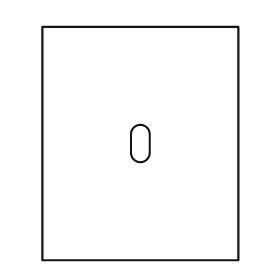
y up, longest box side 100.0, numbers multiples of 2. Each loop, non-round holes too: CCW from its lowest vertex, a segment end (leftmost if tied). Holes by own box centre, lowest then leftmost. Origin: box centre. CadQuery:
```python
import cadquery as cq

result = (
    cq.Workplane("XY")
    .moveTo(-42.0, -50.0)
    .lineTo(42.0, -50.0)
    .lineTo(42.0, 50.0)
    .lineTo(-42.0, 50.0)
    .close()
    .moveTo(-4.0, -4.0)
    .threePointArc((0.0, -8.0), (4.0, -4.0))
    .lineTo(4.0, 4.0)
    .threePointArc((0.0, 8.0), (-4.0, 4.0))
    .close()
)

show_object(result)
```